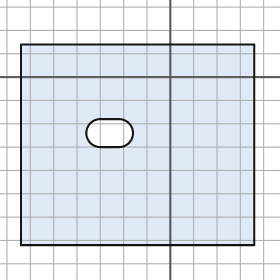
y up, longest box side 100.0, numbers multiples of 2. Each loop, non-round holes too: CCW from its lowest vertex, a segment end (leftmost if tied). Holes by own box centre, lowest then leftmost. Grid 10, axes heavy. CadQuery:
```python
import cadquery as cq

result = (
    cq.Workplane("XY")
    .moveTo(-64.0, -72.0)
    .lineTo(36.0, -72.0)
    .lineTo(36.0, 14.0)
    .lineTo(-64.0, 14.0)
    .close()
    .moveTo(-30.0, -30.0)
    .lineTo(-22.0, -30.0)
    .threePointArc((-16.0, -24.0), (-22.0, -18.0))
    .lineTo(-30.0, -18.0)
    .threePointArc((-36.0, -24.0), (-30.0, -30.0))
    .close()
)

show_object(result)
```